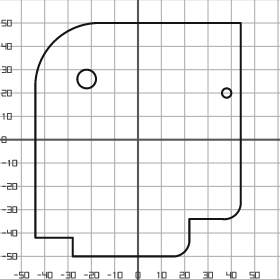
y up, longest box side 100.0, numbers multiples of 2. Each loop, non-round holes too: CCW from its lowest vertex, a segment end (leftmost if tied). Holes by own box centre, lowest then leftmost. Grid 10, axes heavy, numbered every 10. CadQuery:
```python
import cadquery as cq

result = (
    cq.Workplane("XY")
    .moveTo(-28.0, -50.0)
    .lineTo(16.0, -50.0)
    .threePointArc((20.0, -48.0), (22.0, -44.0))
    .lineTo(22.0, -34.0)
    .lineTo(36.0, -34.0)
    .threePointArc((42.0, -32.0), (44.0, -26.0))
    .lineTo(44.0, 50.0)
    .lineTo(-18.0, 50.0)
    .threePointArc((-36.0, 42.0), (-44.0, 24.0))
    .lineTo(-44.0, -42.0)
    .lineTo(-28.0, -42.0)
    .close()
    .moveTo(38.0, 20.0)
    .circle(2.0)
    .moveTo(-22.0, 26.0)
    .circle(4.0)
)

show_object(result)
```